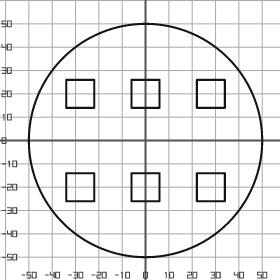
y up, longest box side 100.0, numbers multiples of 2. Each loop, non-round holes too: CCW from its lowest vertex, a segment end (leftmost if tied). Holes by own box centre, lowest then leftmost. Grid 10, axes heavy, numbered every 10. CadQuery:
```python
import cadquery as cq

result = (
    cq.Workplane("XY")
    .moveTo(0.0, 0.0)
    .circle(50.0)
    .moveTo(-34.0, -26.0)
    .lineTo(-22.0, -26.0)
    .lineTo(-22.0, -14.0)
    .lineTo(-34.0, -14.0)
    .close()
    .moveTo(-6.0, -26.0)
    .lineTo(6.0, -26.0)
    .lineTo(6.0, -14.0)
    .lineTo(-6.0, -14.0)
    .close()
    .moveTo(22.0, -26.0)
    .lineTo(34.0, -26.0)
    .lineTo(34.0, -14.0)
    .lineTo(22.0, -14.0)
    .close()
    .moveTo(-34.0, 14.0)
    .lineTo(-22.0, 14.0)
    .lineTo(-22.0, 26.0)
    .lineTo(-34.0, 26.0)
    .close()
    .moveTo(-6.0, 14.0)
    .lineTo(6.0, 14.0)
    .lineTo(6.0, 26.0)
    .lineTo(-6.0, 26.0)
    .close()
    .moveTo(22.0, 14.0)
    .lineTo(34.0, 14.0)
    .lineTo(34.0, 26.0)
    .lineTo(22.0, 26.0)
    .close()
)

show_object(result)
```